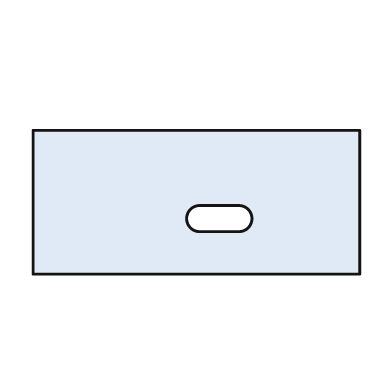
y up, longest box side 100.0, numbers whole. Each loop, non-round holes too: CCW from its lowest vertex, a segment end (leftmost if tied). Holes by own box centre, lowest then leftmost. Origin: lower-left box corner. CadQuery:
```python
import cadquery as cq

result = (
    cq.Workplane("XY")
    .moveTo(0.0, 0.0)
    .lineTo(100.0, 0.0)
    .lineTo(100.0, 44.0)
    .lineTo(0.0, 44.0)
    .close()
    .moveTo(51.0, 13.0)
    .lineTo(63.0, 13.0)
    .threePointArc((67.0, 17.0), (63.0, 21.0))
    .lineTo(51.0, 21.0)
    .threePointArc((47.0, 17.0), (51.0, 13.0))
    .close()
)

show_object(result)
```